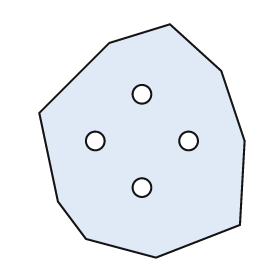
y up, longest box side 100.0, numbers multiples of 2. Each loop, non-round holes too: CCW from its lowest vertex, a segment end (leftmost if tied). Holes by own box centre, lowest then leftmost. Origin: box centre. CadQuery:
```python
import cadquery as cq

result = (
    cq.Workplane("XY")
    .moveTo(6.0, -50.0)
    .lineTo(42.0, -36.0)
    .lineTo(44.0, 0.0)
    .lineTo(34.0, 30.0)
    .lineTo(12.0, 50.0)
    .lineTo(-14.0, 42.0)
    .lineTo(-44.0, 12.0)
    .lineTo(-36.0, -26.0)
    .lineTo(-24.0, -42.0)
    .close()
    .moveTo(0.0, -20.0)
    .circle(4.0)
    .moveTo(-20.0, 0.0)
    .circle(4.0)
    .moveTo(20.0, 0.0)
    .circle(4.0)
    .moveTo(0.0, 20.0)
    .circle(4.0)
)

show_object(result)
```